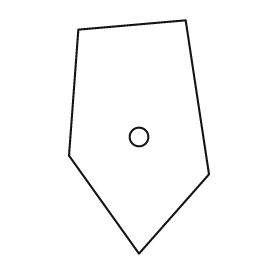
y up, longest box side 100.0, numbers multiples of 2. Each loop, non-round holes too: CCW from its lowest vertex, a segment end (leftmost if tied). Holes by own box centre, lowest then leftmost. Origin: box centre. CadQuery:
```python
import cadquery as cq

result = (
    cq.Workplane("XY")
    .moveTo(0.0, -50.0)
    .lineTo(30.0, -16.0)
    .lineTo(20.0, 50.0)
    .lineTo(-26.0, 46.0)
    .lineTo(-30.0, -8.0)
    .close()
    .moveTo(0.0, 0.0)
    .circle(4.0)
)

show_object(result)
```